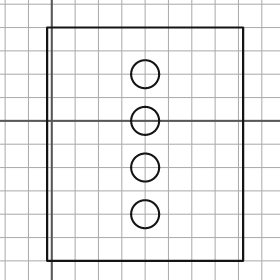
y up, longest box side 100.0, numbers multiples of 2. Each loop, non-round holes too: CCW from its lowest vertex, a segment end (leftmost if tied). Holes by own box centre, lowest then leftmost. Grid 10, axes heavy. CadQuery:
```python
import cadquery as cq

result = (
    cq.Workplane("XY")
    .moveTo(-2.0, -60.0)
    .lineTo(82.0, -60.0)
    .lineTo(82.0, 40.0)
    .lineTo(-2.0, 40.0)
    .close()
    .moveTo(40.0, -40.0)
    .circle(6.0)
    .moveTo(40.0, -20.0)
    .circle(6.0)
    .moveTo(40.0, 0.0)
    .circle(6.0)
    .moveTo(40.0, 20.0)
    .circle(6.0)
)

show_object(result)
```